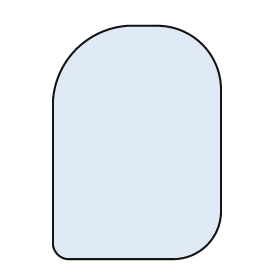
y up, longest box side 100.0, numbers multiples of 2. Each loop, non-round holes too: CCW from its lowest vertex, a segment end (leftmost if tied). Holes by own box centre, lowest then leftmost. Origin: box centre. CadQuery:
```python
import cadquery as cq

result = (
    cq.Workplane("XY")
    .moveTo(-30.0, -50.0)
    .lineTo(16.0, -50.0)
    .threePointArc((30.0, -44.0), (36.0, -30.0))
    .lineTo(36.0, 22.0)
    .threePointArc((28.0, 42.0), (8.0, 50.0))
    .lineTo(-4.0, 50.0)
    .threePointArc((-26.0, 40.0), (-36.0, 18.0))
    .lineTo(-36.0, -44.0)
    .threePointArc((-34.0, -48.0), (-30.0, -50.0))
    .close()
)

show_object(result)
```